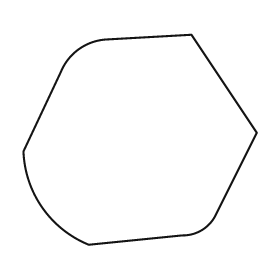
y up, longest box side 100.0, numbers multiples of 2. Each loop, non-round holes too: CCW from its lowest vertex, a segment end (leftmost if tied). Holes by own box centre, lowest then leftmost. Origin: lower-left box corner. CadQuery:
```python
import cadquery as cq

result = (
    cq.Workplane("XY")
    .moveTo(28.0, 0.0)
    .lineTo(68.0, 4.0)
    .threePointArc((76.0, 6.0), (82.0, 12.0))
    .lineTo(100.0, 48.0)
    .lineTo(72.0, 90.0)
    .lineTo(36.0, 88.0)
    .threePointArc((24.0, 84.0), (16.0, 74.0))
    .lineTo(0.0, 40.0)
    .threePointArc((8.0, 16.0), (28.0, 0.0))
    .close()
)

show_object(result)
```